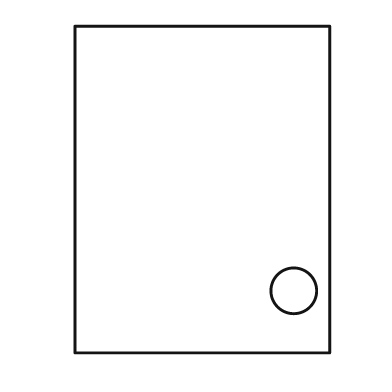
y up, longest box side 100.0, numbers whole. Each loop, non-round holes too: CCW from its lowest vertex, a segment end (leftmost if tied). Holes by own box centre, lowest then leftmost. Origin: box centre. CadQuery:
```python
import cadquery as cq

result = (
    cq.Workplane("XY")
    .moveTo(-39.0, -50.0)
    .lineTo(39.0, -50.0)
    .lineTo(39.0, 50.0)
    .lineTo(-39.0, 50.0)
    .close()
    .moveTo(28.0, -31.0)
    .circle(7.0)
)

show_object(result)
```